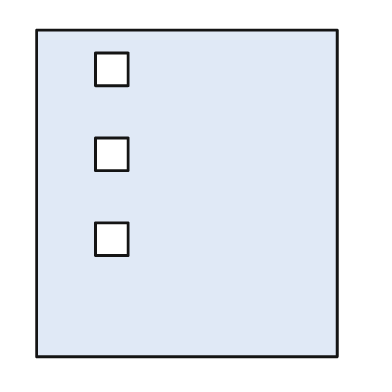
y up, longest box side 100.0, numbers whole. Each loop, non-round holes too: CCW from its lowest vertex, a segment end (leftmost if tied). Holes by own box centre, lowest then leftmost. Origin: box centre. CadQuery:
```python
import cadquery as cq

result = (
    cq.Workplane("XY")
    .moveTo(-46.0, -50.0)
    .lineTo(46.0, -50.0)
    .lineTo(46.0, 50.0)
    .lineTo(-46.0, 50.0)
    .close()
    .moveTo(-28.0, -19.0)
    .lineTo(-18.0, -19.0)
    .lineTo(-18.0, -9.0)
    .lineTo(-28.0, -9.0)
    .close()
    .moveTo(-28.0, 7.0)
    .lineTo(-18.0, 7.0)
    .lineTo(-18.0, 17.0)
    .lineTo(-28.0, 17.0)
    .close()
    .moveTo(-28.0, 33.0)
    .lineTo(-18.0, 33.0)
    .lineTo(-18.0, 43.0)
    .lineTo(-28.0, 43.0)
    .close()
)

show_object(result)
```